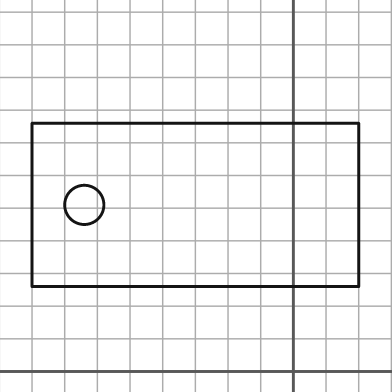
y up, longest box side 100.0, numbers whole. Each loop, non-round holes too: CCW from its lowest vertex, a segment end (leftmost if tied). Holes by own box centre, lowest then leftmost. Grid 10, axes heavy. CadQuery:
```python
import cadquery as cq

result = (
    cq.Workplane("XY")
    .moveTo(-80.0, 26.0)
    .lineTo(20.0, 26.0)
    .lineTo(20.0, 76.0)
    .lineTo(-80.0, 76.0)
    .close()
    .moveTo(-64.0, 51.0)
    .circle(6.0)
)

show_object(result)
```